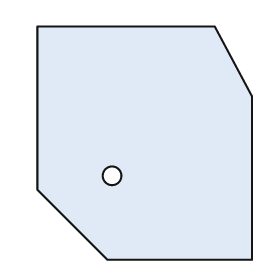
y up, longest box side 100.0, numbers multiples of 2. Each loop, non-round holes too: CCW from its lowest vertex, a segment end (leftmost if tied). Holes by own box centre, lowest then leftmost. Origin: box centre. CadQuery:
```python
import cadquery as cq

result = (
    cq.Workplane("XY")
    .moveTo(-16.0, -50.0)
    .lineTo(46.0, -50.0)
    .lineTo(46.0, 20.0)
    .lineTo(30.0, 50.0)
    .lineTo(-46.0, 50.0)
    .lineTo(-46.0, -20.0)
    .close()
    .moveTo(-14.0, -14.0)
    .circle(4.0)
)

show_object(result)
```